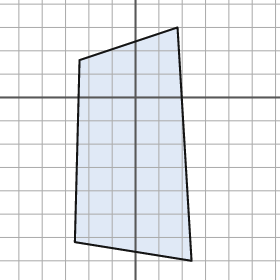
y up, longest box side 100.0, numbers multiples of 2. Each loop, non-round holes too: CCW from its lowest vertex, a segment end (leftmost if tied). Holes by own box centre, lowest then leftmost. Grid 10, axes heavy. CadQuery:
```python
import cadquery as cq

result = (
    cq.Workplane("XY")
    .moveTo(24.0, -70.0)
    .lineTo(18.0, 30.0)
    .lineTo(-24.0, 16.0)
    .lineTo(-26.0, -62.0)
    .close()
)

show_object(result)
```